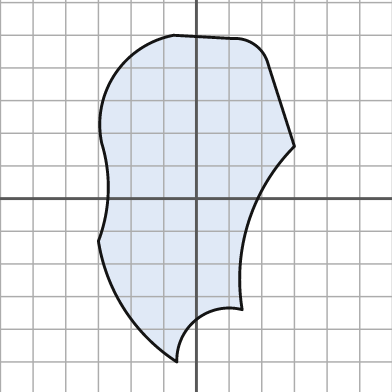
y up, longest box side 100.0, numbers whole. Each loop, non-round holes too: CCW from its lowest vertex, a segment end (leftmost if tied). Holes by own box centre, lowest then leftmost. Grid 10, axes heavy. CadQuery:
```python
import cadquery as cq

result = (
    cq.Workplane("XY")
    .moveTo(-6.0, -50.0)
    .threePointArc((0.0, -37.0), (14.0, -34.0))
    .threePointArc((16.0, -7.0), (30.0, 16.0))
    .lineTo(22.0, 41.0)
    .threePointArc((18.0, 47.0), (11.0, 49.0))
    .lineTo(-7.0, 50.0)
    .threePointArc((-25.0, 38.0), (-29.0, 17.0))
    .threePointArc((-27.0, 2.0), (-30.0, -13.0))
    .threePointArc((-22.0, -34.0), (-6.0, -50.0))
    .close()
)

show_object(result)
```